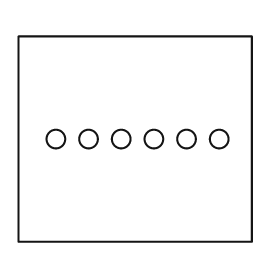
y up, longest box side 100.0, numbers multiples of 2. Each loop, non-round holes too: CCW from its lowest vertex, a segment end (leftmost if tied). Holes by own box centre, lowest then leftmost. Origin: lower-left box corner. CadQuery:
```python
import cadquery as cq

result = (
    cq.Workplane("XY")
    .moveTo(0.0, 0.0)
    .lineTo(100.0, 0.0)
    .lineTo(100.0, 88.0)
    .lineTo(0.0, 88.0)
    .close()
    .moveTo(16.0, 44.0)
    .circle(4.0)
    .moveTo(30.0, 44.0)
    .circle(4.0)
    .moveTo(44.0, 44.0)
    .circle(4.0)
    .moveTo(58.0, 44.0)
    .circle(4.0)
    .moveTo(72.0, 44.0)
    .circle(4.0)
    .moveTo(86.0, 44.0)
    .circle(4.0)
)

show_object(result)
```